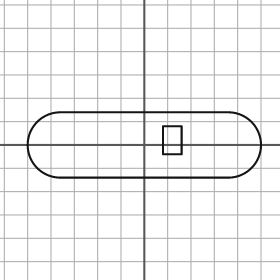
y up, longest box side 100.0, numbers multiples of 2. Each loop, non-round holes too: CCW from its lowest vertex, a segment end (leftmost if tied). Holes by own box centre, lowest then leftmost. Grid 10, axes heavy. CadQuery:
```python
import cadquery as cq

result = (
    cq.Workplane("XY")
    .moveTo(-36.0, -14.0)
    .lineTo(36.0, -14.0)
    .threePointArc((50.0, 0.0), (36.0, 14.0))
    .lineTo(-36.0, 14.0)
    .threePointArc((-50.0, 0.0), (-36.0, -14.0))
    .close()
    .moveTo(8.0, -4.0)
    .lineTo(16.0, -4.0)
    .lineTo(16.0, 8.0)
    .lineTo(8.0, 8.0)
    .close()
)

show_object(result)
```